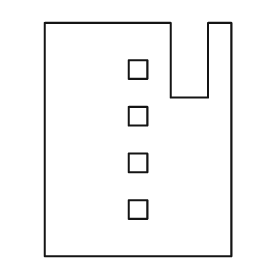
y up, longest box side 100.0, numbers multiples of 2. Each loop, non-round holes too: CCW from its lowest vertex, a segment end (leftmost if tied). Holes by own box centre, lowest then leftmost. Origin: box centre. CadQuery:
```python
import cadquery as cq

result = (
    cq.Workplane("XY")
    .moveTo(-40.0, -50.0)
    .lineTo(40.0, -50.0)
    .lineTo(40.0, 50.0)
    .lineTo(30.0, 50.0)
    .lineTo(30.0, 18.0)
    .lineTo(14.0, 18.0)
    .lineTo(14.0, 50.0)
    .lineTo(-40.0, 50.0)
    .close()
    .moveTo(-4.0, -34.0)
    .lineTo(4.0, -34.0)
    .lineTo(4.0, -26.0)
    .lineTo(-4.0, -26.0)
    .close()
    .moveTo(-4.0, -14.0)
    .lineTo(4.0, -14.0)
    .lineTo(4.0, -6.0)
    .lineTo(-4.0, -6.0)
    .close()
    .moveTo(-4.0, 6.0)
    .lineTo(4.0, 6.0)
    .lineTo(4.0, 14.0)
    .lineTo(-4.0, 14.0)
    .close()
    .moveTo(-4.0, 26.0)
    .lineTo(4.0, 26.0)
    .lineTo(4.0, 34.0)
    .lineTo(-4.0, 34.0)
    .close()
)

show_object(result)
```